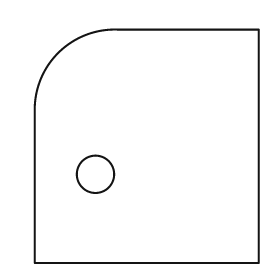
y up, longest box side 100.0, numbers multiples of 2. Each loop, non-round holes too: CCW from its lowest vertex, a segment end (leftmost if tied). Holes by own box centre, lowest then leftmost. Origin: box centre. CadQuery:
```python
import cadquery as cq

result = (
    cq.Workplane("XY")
    .moveTo(-48.0, -50.0)
    .lineTo(48.0, -50.0)
    .lineTo(48.0, 50.0)
    .lineTo(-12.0, 50.0)
    .threePointArc((-38.0, 40.0), (-48.0, 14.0))
    .close()
    .moveTo(-22.0, -12.0)
    .circle(8.0)
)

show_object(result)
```